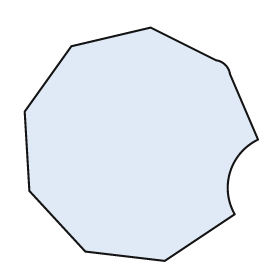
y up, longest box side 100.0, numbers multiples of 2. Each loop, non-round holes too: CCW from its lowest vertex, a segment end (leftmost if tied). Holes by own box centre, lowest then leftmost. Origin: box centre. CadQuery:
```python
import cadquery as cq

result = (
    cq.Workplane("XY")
    .moveTo(10.0, -50.0)
    .lineTo(40.0, -30.0)
    .threePointArc((38.0, -12.0), (50.0, 2.0))
    .lineTo(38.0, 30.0)
    .threePointArc((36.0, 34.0), (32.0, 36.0))
    .lineTo(4.0, 50.0)
    .lineTo(-30.0, 42.0)
    .lineTo(-50.0, 14.0)
    .lineTo(-48.0, -20.0)
    .lineTo(-24.0, -46.0)
    .close()
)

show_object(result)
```